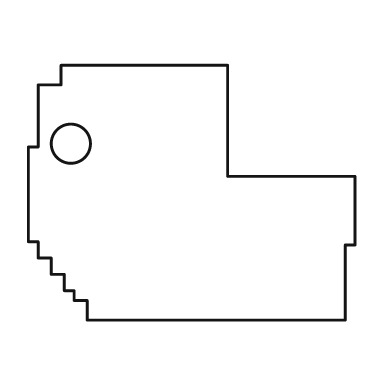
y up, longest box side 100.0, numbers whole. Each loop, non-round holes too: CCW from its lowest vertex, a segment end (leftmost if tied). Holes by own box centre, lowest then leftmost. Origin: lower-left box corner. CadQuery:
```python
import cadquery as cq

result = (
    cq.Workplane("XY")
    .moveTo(18.0, 0.0)
    .lineTo(97.0, 0.0)
    .lineTo(97.0, 23.0)
    .lineTo(100.0, 23.0)
    .lineTo(100.0, 44.0)
    .lineTo(61.0, 44.0)
    .lineTo(61.0, 78.0)
    .lineTo(10.0, 78.0)
    .lineTo(10.0, 72.0)
    .lineTo(3.0, 72.0)
    .lineTo(3.0, 53.0)
    .lineTo(0.0, 53.0)
    .lineTo(0.0, 24.0)
    .lineTo(3.0, 24.0)
    .lineTo(3.0, 19.0)
    .lineTo(7.0, 19.0)
    .lineTo(7.0, 14.0)
    .lineTo(11.0, 14.0)
    .lineTo(11.0, 9.0)
    .lineTo(14.0, 9.0)
    .lineTo(14.0, 6.0)
    .lineTo(18.0, 6.0)
    .close()
    .moveTo(13.0, 54.0)
    .circle(6.0)
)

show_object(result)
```